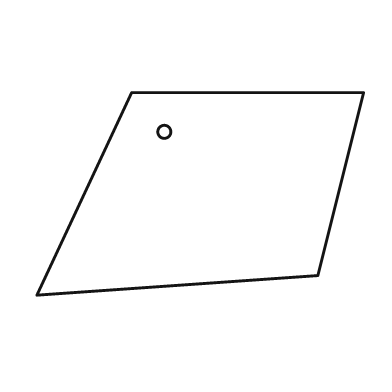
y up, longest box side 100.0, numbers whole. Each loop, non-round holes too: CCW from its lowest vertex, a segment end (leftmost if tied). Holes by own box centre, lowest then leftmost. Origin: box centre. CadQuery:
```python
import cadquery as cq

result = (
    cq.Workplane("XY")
    .moveTo(-50.0, -31.0)
    .lineTo(36.0, -25.0)
    .lineTo(50.0, 31.0)
    .lineTo(-21.0, 31.0)
    .close()
    .moveTo(-11.0, 19.0)
    .circle(2.0)
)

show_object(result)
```